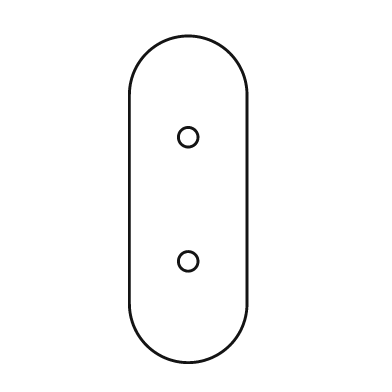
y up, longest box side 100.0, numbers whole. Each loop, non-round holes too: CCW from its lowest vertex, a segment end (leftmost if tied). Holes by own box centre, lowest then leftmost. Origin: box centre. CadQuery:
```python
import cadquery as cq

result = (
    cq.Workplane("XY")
    .moveTo(-18.0, -32.0)
    .threePointArc((0.0, -50.0), (18.0, -32.0))
    .lineTo(18.0, 32.0)
    .threePointArc((0.0, 50.0), (-18.0, 32.0))
    .close()
    .moveTo(0.0, -19.0)
    .circle(3.0)
    .moveTo(0.0, 19.0)
    .circle(3.0)
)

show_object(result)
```